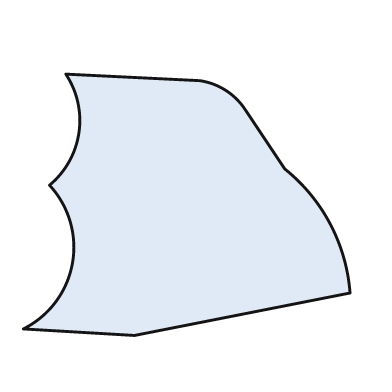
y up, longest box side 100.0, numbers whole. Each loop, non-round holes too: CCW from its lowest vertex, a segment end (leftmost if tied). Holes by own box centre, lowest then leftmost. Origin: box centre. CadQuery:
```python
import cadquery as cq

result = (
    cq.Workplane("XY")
    .moveTo(-16.0, -40.0)
    .lineTo(50.0, -27.0)
    .threePointArc((44.0, -6.0), (30.0, 11.0))
    .lineTo(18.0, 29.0)
    .threePointArc((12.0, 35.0), (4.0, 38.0))
    .lineTo(-37.0, 40.0)
    .threePointArc((-33.0, 22.0), (-42.0, 6.0))
    .threePointArc((-35.0, -18.0), (-50.0, -38.0))
    .close()
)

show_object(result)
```